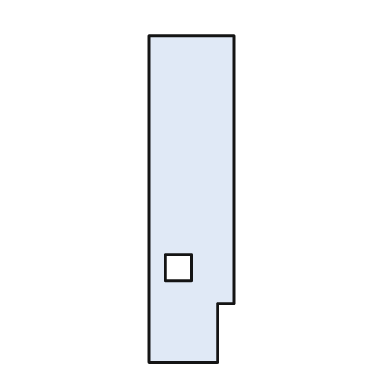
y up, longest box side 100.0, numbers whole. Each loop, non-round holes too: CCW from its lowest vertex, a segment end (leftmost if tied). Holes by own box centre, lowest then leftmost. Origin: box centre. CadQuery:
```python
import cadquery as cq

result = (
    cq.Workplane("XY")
    .moveTo(-13.0, -50.0)
    .lineTo(8.0, -50.0)
    .lineTo(8.0, -32.0)
    .lineTo(13.0, -32.0)
    .lineTo(13.0, 50.0)
    .lineTo(-13.0, 50.0)
    .close()
    .moveTo(-8.0, -25.0)
    .lineTo(0.0, -25.0)
    .lineTo(0.0, -17.0)
    .lineTo(-8.0, -17.0)
    .close()
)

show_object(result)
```